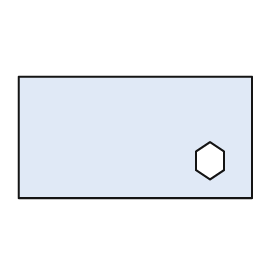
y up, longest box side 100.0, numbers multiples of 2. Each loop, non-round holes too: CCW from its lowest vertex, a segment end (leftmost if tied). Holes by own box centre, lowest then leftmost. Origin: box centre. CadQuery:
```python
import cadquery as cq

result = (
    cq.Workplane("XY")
    .moveTo(-50.0, -26.0)
    .lineTo(50.0, -26.0)
    .lineTo(50.0, 26.0)
    .lineTo(-50.0, 26.0)
    .close()
    .moveTo(32.0, -18.0)
    .lineTo(38.0, -14.0)
    .lineTo(38.0, -6.0)
    .lineTo(32.0, -2.0)
    .lineTo(26.0, -6.0)
    .lineTo(26.0, -14.0)
    .close()
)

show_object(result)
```